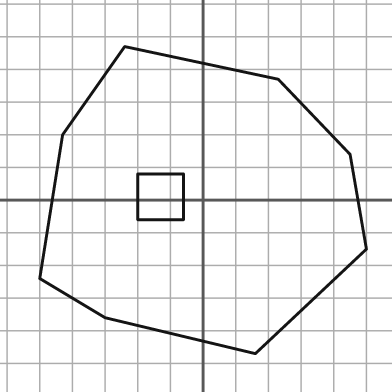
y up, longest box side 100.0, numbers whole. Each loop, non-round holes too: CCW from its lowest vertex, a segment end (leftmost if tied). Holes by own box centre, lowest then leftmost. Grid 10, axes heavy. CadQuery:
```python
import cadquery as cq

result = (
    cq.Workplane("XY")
    .moveTo(16.0, -47.0)
    .lineTo(50.0, -15.0)
    .lineTo(45.0, 14.0)
    .lineTo(23.0, 37.0)
    .lineTo(-24.0, 47.0)
    .lineTo(-43.0, 20.0)
    .lineTo(-50.0, -24.0)
    .lineTo(-30.0, -36.0)
    .close()
    .moveTo(-20.0, -6.0)
    .lineTo(-6.0, -6.0)
    .lineTo(-6.0, 8.0)
    .lineTo(-20.0, 8.0)
    .close()
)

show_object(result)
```